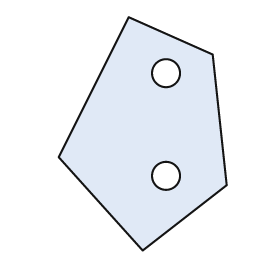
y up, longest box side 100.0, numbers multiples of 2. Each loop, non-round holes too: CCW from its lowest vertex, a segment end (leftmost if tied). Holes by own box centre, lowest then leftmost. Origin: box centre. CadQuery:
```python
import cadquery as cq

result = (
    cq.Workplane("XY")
    .moveTo(0.0, -50.0)
    .lineTo(36.0, -22.0)
    .lineTo(30.0, 34.0)
    .lineTo(-6.0, 50.0)
    .lineTo(-36.0, -10.0)
    .close()
    .moveTo(10.0, -18.0)
    .circle(6.0)
    .moveTo(10.0, 26.0)
    .circle(6.0)
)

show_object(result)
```